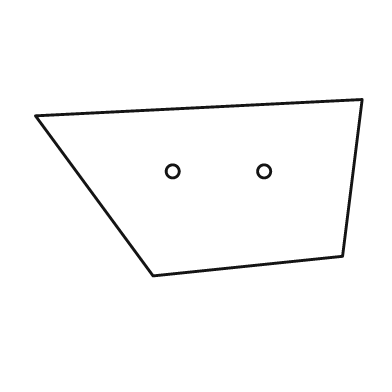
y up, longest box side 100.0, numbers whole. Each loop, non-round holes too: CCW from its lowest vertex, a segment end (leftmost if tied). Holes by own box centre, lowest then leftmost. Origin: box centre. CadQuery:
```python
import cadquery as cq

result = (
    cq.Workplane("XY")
    .moveTo(-14.0, -27.0)
    .lineTo(44.0, -21.0)
    .lineTo(50.0, 27.0)
    .lineTo(-50.0, 22.0)
    .close()
    .moveTo(-8.0, 5.0)
    .circle(2.0)
    .moveTo(20.0, 5.0)
    .circle(2.0)
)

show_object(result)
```